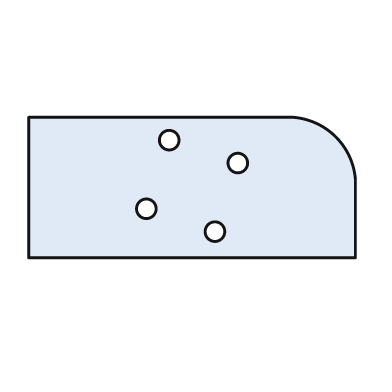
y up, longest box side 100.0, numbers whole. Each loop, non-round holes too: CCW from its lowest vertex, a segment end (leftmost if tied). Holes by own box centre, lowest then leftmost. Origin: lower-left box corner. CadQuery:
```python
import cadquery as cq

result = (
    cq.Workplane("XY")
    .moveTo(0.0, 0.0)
    .lineTo(100.0, 0.0)
    .lineTo(100.0, 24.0)
    .threePointArc((94.0, 37.0), (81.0, 43.0))
    .lineTo(0.0, 43.0)
    .close()
    .moveTo(57.0, 8.0)
    .circle(3.0)
    .moveTo(36.0, 15.0)
    .circle(3.0)
    .moveTo(64.0, 29.0)
    .circle(3.0)
    .moveTo(43.0, 36.0)
    .circle(3.0)
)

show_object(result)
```